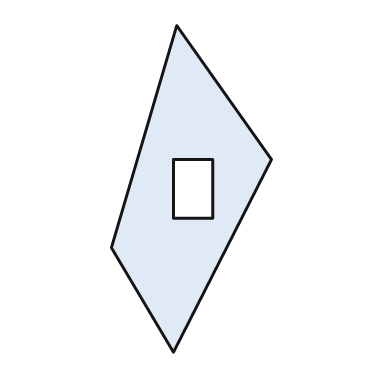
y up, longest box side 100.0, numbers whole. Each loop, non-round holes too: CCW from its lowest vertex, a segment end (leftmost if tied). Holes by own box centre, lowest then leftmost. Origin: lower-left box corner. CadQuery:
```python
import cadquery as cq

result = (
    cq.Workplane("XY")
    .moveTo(19.0, 0.0)
    .lineTo(49.0, 59.0)
    .lineTo(20.0, 100.0)
    .lineTo(0.0, 32.0)
    .close()
    .moveTo(19.0, 41.0)
    .lineTo(31.0, 41.0)
    .lineTo(31.0, 59.0)
    .lineTo(19.0, 59.0)
    .close()
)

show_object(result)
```